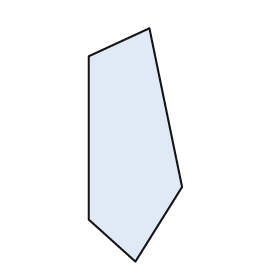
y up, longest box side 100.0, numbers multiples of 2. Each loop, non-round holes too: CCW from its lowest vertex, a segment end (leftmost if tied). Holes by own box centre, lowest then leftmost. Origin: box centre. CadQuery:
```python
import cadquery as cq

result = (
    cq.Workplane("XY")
    .moveTo(0.0, -50.0)
    .lineTo(20.0, -18.0)
    .lineTo(6.0, 50.0)
    .lineTo(-20.0, 38.0)
    .lineTo(-20.0, -32.0)
    .close()
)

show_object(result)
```